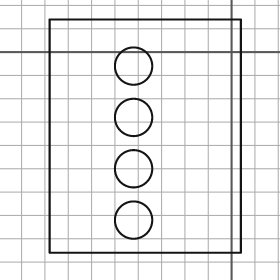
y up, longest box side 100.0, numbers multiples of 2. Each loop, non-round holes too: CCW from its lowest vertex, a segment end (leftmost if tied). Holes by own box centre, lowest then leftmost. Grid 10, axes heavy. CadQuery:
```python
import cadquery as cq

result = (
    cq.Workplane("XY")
    .moveTo(-78.0, -86.0)
    .lineTo(4.0, -86.0)
    .lineTo(4.0, 14.0)
    .lineTo(-78.0, 14.0)
    .close()
    .moveTo(-42.0, -72.0)
    .circle(8.0)
    .moveTo(-42.0, -50.0)
    .circle(8.0)
    .moveTo(-42.0, -28.0)
    .circle(8.0)
    .moveTo(-42.0, -6.0)
    .circle(8.0)
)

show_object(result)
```